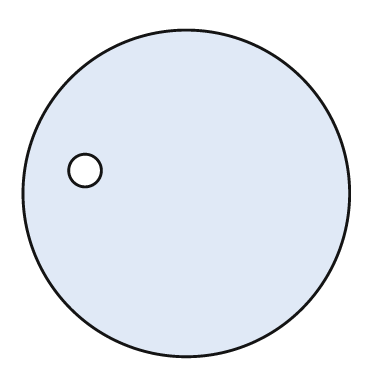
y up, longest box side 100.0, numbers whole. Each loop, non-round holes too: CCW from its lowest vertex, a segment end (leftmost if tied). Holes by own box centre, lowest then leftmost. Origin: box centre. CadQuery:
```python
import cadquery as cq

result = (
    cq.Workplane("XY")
    .moveTo(0.0, 0.0)
    .circle(50.0)
    .moveTo(-31.0, 7.0)
    .circle(5.0)
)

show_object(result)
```